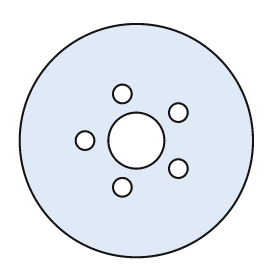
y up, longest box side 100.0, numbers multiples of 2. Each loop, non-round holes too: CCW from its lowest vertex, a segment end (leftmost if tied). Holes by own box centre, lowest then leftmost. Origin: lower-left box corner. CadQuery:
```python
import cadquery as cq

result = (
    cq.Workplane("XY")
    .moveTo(50.0, 50.0)
    .circle(50.0)
    .moveTo(44.0, 30.0)
    .circle(4.0)
    .moveTo(68.0, 38.0)
    .circle(4.0)
    .moveTo(28.0, 50.0)
    .circle(4.0)
    .moveTo(50.0, 50.0)
    .circle(12.0)
    .moveTo(68.0, 62.0)
    .circle(4.0)
    .moveTo(44.0, 70.0)
    .circle(4.0)
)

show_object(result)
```